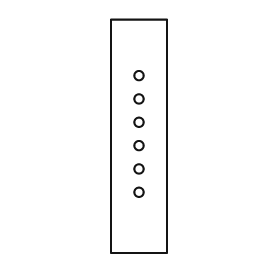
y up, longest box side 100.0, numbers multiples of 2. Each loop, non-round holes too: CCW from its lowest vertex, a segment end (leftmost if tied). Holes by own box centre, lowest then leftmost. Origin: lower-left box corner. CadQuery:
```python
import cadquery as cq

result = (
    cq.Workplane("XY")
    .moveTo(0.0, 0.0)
    .lineTo(24.0, 0.0)
    .lineTo(24.0, 100.0)
    .lineTo(0.0, 100.0)
    .close()
    .moveTo(12.0, 26.0)
    .circle(2.0)
    .moveTo(12.0, 36.0)
    .circle(2.0)
    .moveTo(12.0, 46.0)
    .circle(2.0)
    .moveTo(12.0, 56.0)
    .circle(2.0)
    .moveTo(12.0, 66.0)
    .circle(2.0)
    .moveTo(12.0, 76.0)
    .circle(2.0)
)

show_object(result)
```